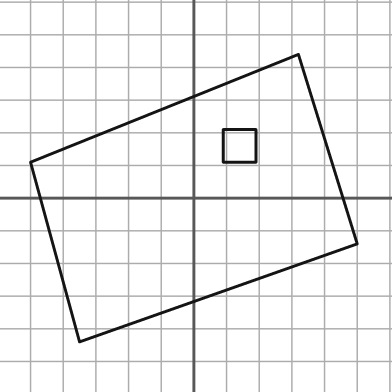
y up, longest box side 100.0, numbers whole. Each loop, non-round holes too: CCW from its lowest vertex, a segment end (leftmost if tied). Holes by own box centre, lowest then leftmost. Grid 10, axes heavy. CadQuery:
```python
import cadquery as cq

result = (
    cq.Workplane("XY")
    .moveTo(-35.0, -44.0)
    .lineTo(50.0, -14.0)
    .lineTo(32.0, 44.0)
    .lineTo(-50.0, 11.0)
    .close()
    .moveTo(9.0, 11.0)
    .lineTo(19.0, 11.0)
    .lineTo(19.0, 21.0)
    .lineTo(9.0, 21.0)
    .close()
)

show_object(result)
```